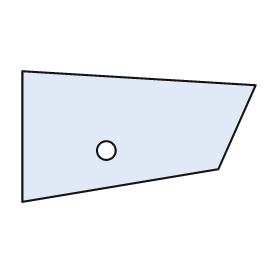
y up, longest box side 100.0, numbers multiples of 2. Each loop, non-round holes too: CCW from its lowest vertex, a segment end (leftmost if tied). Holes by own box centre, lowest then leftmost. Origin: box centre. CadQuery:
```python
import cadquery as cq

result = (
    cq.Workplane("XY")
    .moveTo(-50.0, -28.0)
    .lineTo(34.0, -14.0)
    .lineTo(50.0, 22.0)
    .lineTo(-50.0, 28.0)
    .close()
    .moveTo(-14.0, -6.0)
    .circle(4.0)
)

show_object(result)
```